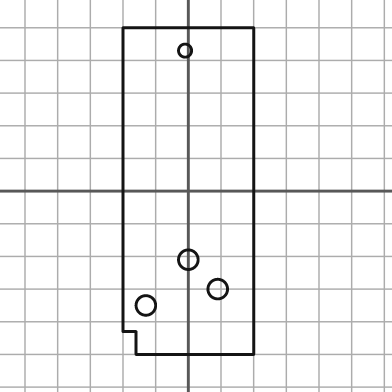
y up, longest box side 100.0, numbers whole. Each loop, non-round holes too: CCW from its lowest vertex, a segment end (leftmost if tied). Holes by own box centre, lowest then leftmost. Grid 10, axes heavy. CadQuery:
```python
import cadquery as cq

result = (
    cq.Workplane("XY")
    .moveTo(-16.0, -50.0)
    .lineTo(20.0, -50.0)
    .lineTo(20.0, 50.0)
    .lineTo(-20.0, 50.0)
    .lineTo(-20.0, -43.0)
    .lineTo(-16.0, -43.0)
    .close()
    .moveTo(-13.0, -35.0)
    .circle(3.0)
    .moveTo(9.0, -30.0)
    .circle(3.0)
    .moveTo(0.0, -21.0)
    .circle(3.0)
    .moveTo(-1.0, 43.0)
    .circle(2.0)
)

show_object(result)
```